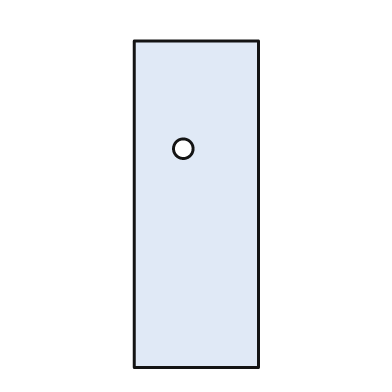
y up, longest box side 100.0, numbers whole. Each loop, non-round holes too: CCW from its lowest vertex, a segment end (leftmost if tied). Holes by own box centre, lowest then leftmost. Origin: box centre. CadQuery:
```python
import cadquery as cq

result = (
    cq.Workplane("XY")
    .moveTo(-19.0, -50.0)
    .lineTo(19.0, -50.0)
    .lineTo(19.0, 50.0)
    .lineTo(-19.0, 50.0)
    .close()
    .moveTo(-4.0, 17.0)
    .circle(3.0)
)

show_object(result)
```